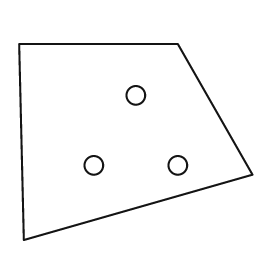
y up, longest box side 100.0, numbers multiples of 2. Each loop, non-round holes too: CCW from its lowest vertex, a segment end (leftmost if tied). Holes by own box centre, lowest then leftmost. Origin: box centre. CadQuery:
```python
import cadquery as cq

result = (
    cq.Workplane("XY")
    .moveTo(-48.0, -42.0)
    .lineTo(50.0, -14.0)
    .lineTo(18.0, 42.0)
    .lineTo(-50.0, 42.0)
    .close()
    .moveTo(-18.0, -10.0)
    .circle(4.0)
    .moveTo(18.0, -10.0)
    .circle(4.0)
    .moveTo(0.0, 20.0)
    .circle(4.0)
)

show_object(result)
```